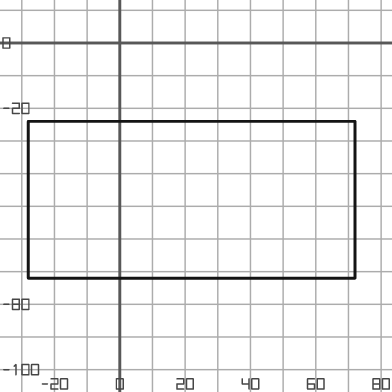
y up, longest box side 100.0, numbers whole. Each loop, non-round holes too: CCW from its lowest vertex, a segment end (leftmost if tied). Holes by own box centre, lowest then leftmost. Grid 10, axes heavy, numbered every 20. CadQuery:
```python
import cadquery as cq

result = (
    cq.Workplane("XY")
    .moveTo(-28.0, -72.0)
    .lineTo(72.0, -72.0)
    .lineTo(72.0, -24.0)
    .lineTo(-28.0, -24.0)
    .close()
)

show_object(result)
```